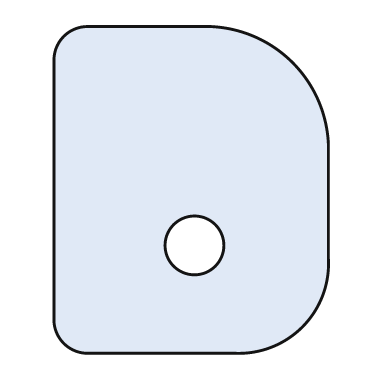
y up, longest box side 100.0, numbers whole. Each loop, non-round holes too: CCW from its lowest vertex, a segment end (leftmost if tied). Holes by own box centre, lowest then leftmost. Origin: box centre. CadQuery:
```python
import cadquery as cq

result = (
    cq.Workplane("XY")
    .moveTo(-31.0, -50.0)
    .lineTo(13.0, -50.0)
    .threePointArc((34.0, -42.0), (42.0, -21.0))
    .lineTo(42.0, 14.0)
    .threePointArc((31.0, 39.0), (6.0, 50.0))
    .lineTo(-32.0, 50.0)
    .threePointArc((-39.0, 47.0), (-42.0, 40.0))
    .lineTo(-42.0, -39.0)
    .threePointArc((-39.0, -47.0), (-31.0, -50.0))
    .close()
    .moveTo(1.0, -17.0)
    .circle(9.0)
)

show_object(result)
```